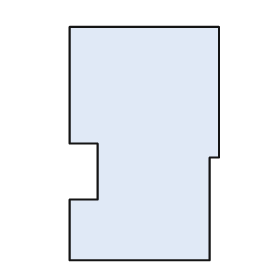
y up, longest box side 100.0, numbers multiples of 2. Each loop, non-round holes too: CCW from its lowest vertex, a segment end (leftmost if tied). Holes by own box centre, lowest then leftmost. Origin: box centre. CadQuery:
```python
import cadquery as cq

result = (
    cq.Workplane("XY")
    .moveTo(-32.0, -50.0)
    .lineTo(28.0, -50.0)
    .lineTo(28.0, -6.0)
    .lineTo(32.0, -6.0)
    .lineTo(32.0, 50.0)
    .lineTo(-32.0, 50.0)
    .lineTo(-32.0, 0.0)
    .lineTo(-20.0, 0.0)
    .lineTo(-20.0, -24.0)
    .lineTo(-32.0, -24.0)
    .close()
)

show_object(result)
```